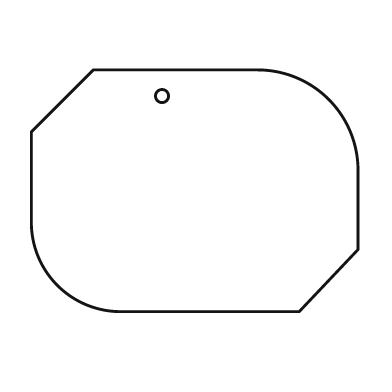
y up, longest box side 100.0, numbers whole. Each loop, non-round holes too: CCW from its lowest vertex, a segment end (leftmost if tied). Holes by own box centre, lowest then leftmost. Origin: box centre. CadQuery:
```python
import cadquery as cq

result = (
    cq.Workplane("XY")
    .moveTo(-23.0, -37.0)
    .lineTo(32.0, -37.0)
    .lineTo(50.0, -18.0)
    .lineTo(50.0, 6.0)
    .threePointArc((41.0, 28.0), (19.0, 37.0))
    .lineTo(-31.0, 37.0)
    .lineTo(-50.0, 18.0)
    .lineTo(-50.0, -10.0)
    .threePointArc((-42.0, -29.0), (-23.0, -37.0))
    .close()
    .moveTo(-10.0, 29.0)
    .circle(2.0)
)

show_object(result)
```